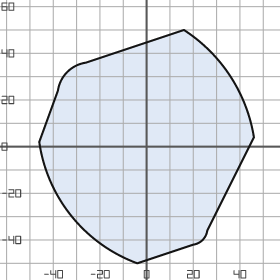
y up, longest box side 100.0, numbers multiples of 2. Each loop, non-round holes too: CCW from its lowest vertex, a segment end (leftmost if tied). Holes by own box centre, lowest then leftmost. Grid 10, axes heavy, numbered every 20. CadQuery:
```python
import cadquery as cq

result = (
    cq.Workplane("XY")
    .moveTo(-4.0, -50.0)
    .lineTo(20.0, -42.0)
    .threePointArc((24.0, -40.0), (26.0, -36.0))
    .lineTo(46.0, 4.0)
    .threePointArc((36.0, 30.0), (16.0, 50.0))
    .lineTo(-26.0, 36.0)
    .threePointArc((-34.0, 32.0), (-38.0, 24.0))
    .lineTo(-46.0, 2.0)
    .threePointArc((-32.0, -30.0), (-4.0, -50.0))
    .close()
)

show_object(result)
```